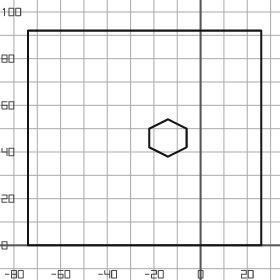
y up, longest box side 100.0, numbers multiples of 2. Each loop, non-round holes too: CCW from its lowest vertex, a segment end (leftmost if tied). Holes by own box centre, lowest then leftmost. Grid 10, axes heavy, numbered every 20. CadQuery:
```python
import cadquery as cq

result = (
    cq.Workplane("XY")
    .moveTo(-74.0, 0.0)
    .lineTo(26.0, 0.0)
    .lineTo(26.0, 92.0)
    .lineTo(-74.0, 92.0)
    .close()
    .moveTo(-14.0, 38.0)
    .lineTo(-6.0, 42.0)
    .lineTo(-6.0, 50.0)
    .lineTo(-14.0, 54.0)
    .lineTo(-22.0, 50.0)
    .lineTo(-22.0, 42.0)
    .close()
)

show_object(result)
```